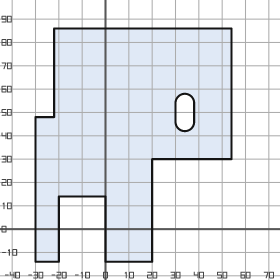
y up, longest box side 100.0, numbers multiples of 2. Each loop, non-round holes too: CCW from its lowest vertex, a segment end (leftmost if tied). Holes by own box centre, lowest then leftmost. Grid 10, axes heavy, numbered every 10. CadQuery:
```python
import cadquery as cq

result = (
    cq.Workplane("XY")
    .moveTo(-30.0, -14.0)
    .lineTo(-20.0, -14.0)
    .lineTo(-20.0, 14.0)
    .lineTo(0.0, 14.0)
    .lineTo(0.0, -14.0)
    .lineTo(20.0, -14.0)
    .lineTo(20.0, 30.0)
    .lineTo(54.0, 30.0)
    .lineTo(54.0, 86.0)
    .lineTo(-22.0, 86.0)
    .lineTo(-22.0, 48.0)
    .lineTo(-30.0, 48.0)
    .close()
    .moveTo(30.0, 46.0)
    .threePointArc((34.0, 42.0), (38.0, 46.0))
    .lineTo(38.0, 54.0)
    .threePointArc((34.0, 58.0), (30.0, 54.0))
    .close()
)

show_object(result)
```